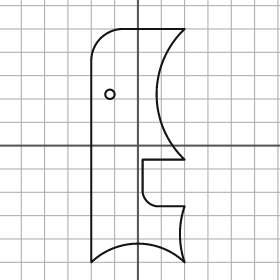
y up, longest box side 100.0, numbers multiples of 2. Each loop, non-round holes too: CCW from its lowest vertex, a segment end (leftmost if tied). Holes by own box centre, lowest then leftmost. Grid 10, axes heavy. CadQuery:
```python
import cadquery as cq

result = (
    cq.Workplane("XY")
    .moveTo(-20.0, -50.0)
    .threePointArc((0.0, -42.0), (20.0, -50.0))
    .threePointArc((18.0, -38.0), (20.0, -26.0))
    .lineTo(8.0, -26.0)
    .threePointArc((4.0, -24.0), (2.0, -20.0))
    .lineTo(2.0, -6.0)
    .lineTo(20.0, -6.0)
    .threePointArc((8.0, 22.0), (20.0, 50.0))
    .lineTo(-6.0, 50.0)
    .threePointArc((-16.0, 46.0), (-20.0, 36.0))
    .close()
    .moveTo(-12.0, 22.0)
    .circle(2.0)
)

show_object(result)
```